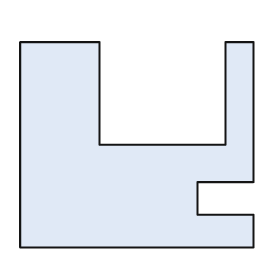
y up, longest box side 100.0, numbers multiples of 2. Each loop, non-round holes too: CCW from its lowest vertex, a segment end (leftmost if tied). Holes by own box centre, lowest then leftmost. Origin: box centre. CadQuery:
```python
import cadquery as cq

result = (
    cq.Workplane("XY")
    .moveTo(-50.0, -44.0)
    .lineTo(50.0, -44.0)
    .lineTo(50.0, -30.0)
    .lineTo(26.0, -30.0)
    .lineTo(26.0, -16.0)
    .lineTo(50.0, -16.0)
    .lineTo(50.0, 44.0)
    .lineTo(38.0, 44.0)
    .lineTo(38.0, 0.0)
    .lineTo(-16.0, 0.0)
    .lineTo(-16.0, 44.0)
    .lineTo(-50.0, 44.0)
    .close()
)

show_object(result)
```